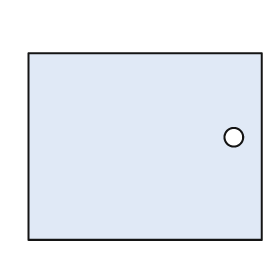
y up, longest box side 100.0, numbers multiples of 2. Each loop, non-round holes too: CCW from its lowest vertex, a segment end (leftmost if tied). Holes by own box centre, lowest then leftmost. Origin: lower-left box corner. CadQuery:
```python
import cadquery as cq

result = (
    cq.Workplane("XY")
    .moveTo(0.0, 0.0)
    .lineTo(100.0, 0.0)
    .lineTo(100.0, 80.0)
    .lineTo(0.0, 80.0)
    .close()
    .moveTo(88.0, 44.0)
    .circle(4.0)
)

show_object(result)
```